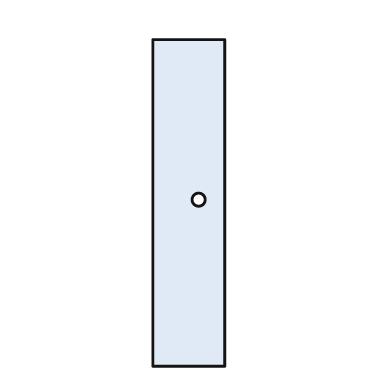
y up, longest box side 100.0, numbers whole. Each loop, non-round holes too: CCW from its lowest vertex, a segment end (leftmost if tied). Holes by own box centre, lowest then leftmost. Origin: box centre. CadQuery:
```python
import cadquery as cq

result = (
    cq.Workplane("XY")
    .moveTo(-11.0, -50.0)
    .lineTo(11.0, -50.0)
    .lineTo(11.0, 50.0)
    .lineTo(-11.0, 50.0)
    .close()
    .moveTo(3.0, 1.0)
    .circle(2.0)
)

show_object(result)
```